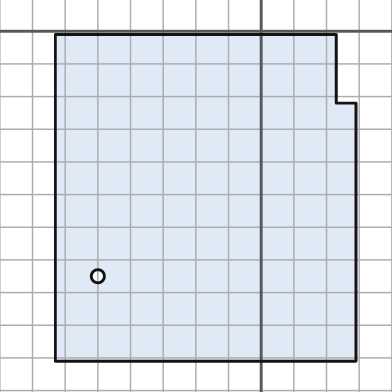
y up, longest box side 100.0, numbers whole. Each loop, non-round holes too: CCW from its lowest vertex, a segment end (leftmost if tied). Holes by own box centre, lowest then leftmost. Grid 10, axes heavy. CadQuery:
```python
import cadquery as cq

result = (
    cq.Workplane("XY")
    .moveTo(-63.0, -101.0)
    .lineTo(29.0, -101.0)
    .lineTo(29.0, -22.0)
    .lineTo(23.0, -22.0)
    .lineTo(23.0, -1.0)
    .lineTo(-63.0, -1.0)
    .close()
    .moveTo(-50.0, -75.0)
    .circle(2.0)
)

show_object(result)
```